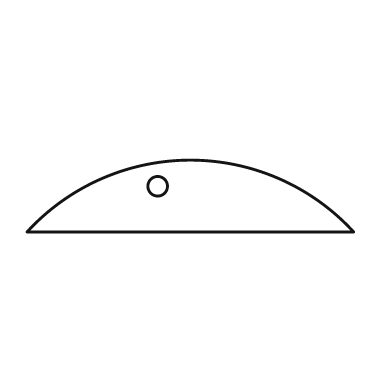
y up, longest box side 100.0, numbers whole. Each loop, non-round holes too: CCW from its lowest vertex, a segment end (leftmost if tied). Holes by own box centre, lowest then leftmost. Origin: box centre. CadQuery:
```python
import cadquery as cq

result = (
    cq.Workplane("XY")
    .moveTo(-50.0, -11.0)
    .lineTo(50.0, -11.0)
    .threePointArc((0.0, 11.0), (-50.0, -11.0))
    .close()
    .moveTo(-10.0, 3.0)
    .circle(3.0)
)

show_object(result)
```